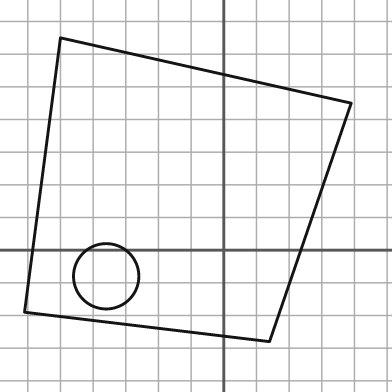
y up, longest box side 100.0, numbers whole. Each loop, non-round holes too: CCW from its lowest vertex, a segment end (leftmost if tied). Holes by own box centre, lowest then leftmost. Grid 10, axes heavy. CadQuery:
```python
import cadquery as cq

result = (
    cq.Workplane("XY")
    .moveTo(14.0, -28.0)
    .lineTo(39.0, 45.0)
    .lineTo(-50.0, 65.0)
    .lineTo(-61.0, -19.0)
    .close()
    .moveTo(-36.0, -8.0)
    .circle(10.0)
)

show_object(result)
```